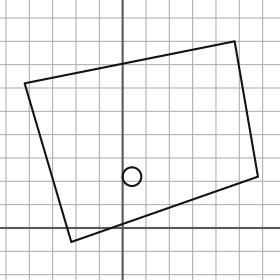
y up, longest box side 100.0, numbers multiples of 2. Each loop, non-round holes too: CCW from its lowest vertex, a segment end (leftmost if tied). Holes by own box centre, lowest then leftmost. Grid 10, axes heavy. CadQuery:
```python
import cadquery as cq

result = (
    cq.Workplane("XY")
    .moveTo(-22.0, -6.0)
    .lineTo(58.0, 22.0)
    .lineTo(48.0, 80.0)
    .lineTo(-42.0, 62.0)
    .close()
    .moveTo(4.0, 22.0)
    .circle(4.0)
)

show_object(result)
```